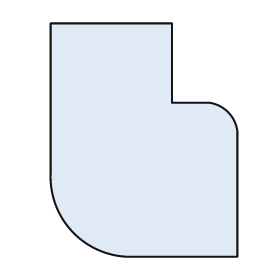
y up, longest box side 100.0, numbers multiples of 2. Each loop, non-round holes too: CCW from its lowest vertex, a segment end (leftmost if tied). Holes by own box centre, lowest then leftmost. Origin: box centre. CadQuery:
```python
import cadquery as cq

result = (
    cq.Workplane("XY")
    .moveTo(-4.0, -50.0)
    .lineTo(40.0, -50.0)
    .lineTo(40.0, 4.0)
    .threePointArc((36.0, 12.0), (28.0, 16.0))
    .lineTo(12.0, 16.0)
    .lineTo(12.0, 50.0)
    .lineTo(-40.0, 50.0)
    .lineTo(-40.0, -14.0)
    .threePointArc((-30.0, -40.0), (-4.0, -50.0))
    .close()
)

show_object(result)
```